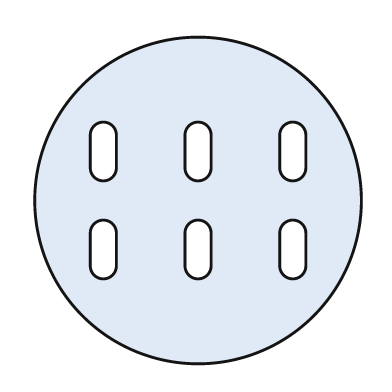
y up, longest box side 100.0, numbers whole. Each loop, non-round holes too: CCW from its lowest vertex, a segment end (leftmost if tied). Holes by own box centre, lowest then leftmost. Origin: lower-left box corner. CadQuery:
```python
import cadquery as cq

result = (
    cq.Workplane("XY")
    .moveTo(50.0, 50.0)
    .circle(50.0)
    .moveTo(17.0, 30.0)
    .threePointArc((21.0, 26.0), (25.0, 30.0))
    .lineTo(25.0, 40.0)
    .threePointArc((21.0, 44.0), (17.0, 40.0))
    .close()
    .moveTo(46.0, 30.0)
    .threePointArc((50.0, 26.0), (54.0, 30.0))
    .lineTo(54.0, 40.0)
    .threePointArc((50.0, 44.0), (46.0, 40.0))
    .close()
    .moveTo(75.0, 30.0)
    .threePointArc((79.0, 26.0), (83.0, 30.0))
    .lineTo(83.0, 40.0)
    .threePointArc((79.0, 44.0), (75.0, 40.0))
    .close()
    .moveTo(17.0, 60.0)
    .threePointArc((21.0, 56.0), (25.0, 60.0))
    .lineTo(25.0, 70.0)
    .threePointArc((21.0, 74.0), (17.0, 70.0))
    .close()
    .moveTo(46.0, 60.0)
    .threePointArc((50.0, 56.0), (54.0, 60.0))
    .lineTo(54.0, 70.0)
    .threePointArc((50.0, 74.0), (46.0, 70.0))
    .close()
    .moveTo(75.0, 60.0)
    .threePointArc((79.0, 56.0), (83.0, 60.0))
    .lineTo(83.0, 70.0)
    .threePointArc((79.0, 74.0), (75.0, 70.0))
    .close()
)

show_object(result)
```